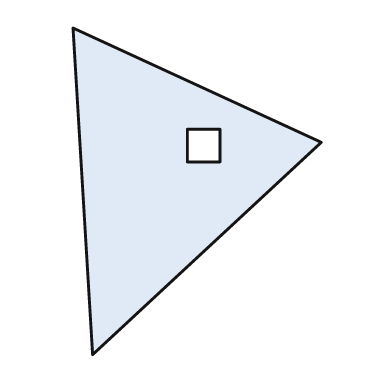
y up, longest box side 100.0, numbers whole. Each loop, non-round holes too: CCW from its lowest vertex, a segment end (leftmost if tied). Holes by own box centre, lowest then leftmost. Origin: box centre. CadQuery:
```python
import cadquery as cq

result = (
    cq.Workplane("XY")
    .moveTo(-32.0, -50.0)
    .lineTo(38.0, 15.0)
    .lineTo(-38.0, 50.0)
    .close()
    .moveTo(-3.0, 9.0)
    .lineTo(7.0, 9.0)
    .lineTo(7.0, 19.0)
    .lineTo(-3.0, 19.0)
    .close()
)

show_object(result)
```